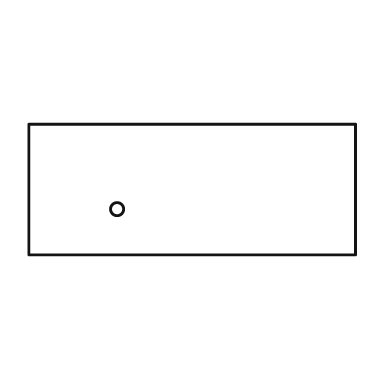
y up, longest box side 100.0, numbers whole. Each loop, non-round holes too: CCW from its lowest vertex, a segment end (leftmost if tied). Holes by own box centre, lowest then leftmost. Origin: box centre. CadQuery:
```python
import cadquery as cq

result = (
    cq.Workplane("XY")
    .moveTo(-50.0, -20.0)
    .lineTo(50.0, -20.0)
    .lineTo(50.0, 20.0)
    .lineTo(-50.0, 20.0)
    .close()
    .moveTo(-23.0, -6.0)
    .circle(2.0)
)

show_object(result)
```